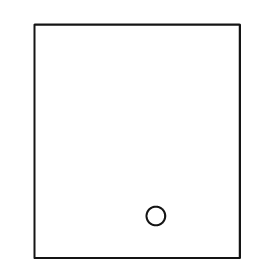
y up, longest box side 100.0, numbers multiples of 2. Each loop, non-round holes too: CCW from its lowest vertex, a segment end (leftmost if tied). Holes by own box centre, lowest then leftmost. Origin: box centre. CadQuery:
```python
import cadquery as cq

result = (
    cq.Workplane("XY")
    .moveTo(-44.0, -50.0)
    .lineTo(44.0, -50.0)
    .lineTo(44.0, 50.0)
    .lineTo(-44.0, 50.0)
    .close()
    .moveTo(8.0, -32.0)
    .circle(4.0)
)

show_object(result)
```